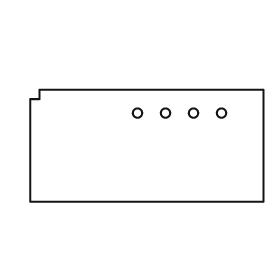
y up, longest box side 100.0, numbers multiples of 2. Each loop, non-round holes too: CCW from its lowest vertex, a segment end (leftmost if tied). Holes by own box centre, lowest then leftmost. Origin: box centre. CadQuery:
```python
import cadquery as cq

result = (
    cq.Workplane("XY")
    .moveTo(-50.0, -24.0)
    .lineTo(50.0, -24.0)
    .lineTo(50.0, 24.0)
    .lineTo(-46.0, 24.0)
    .lineTo(-46.0, 20.0)
    .lineTo(-50.0, 20.0)
    .close()
    .moveTo(-4.0, 14.0)
    .circle(2.0)
    .moveTo(8.0, 14.0)
    .circle(2.0)
    .moveTo(20.0, 14.0)
    .circle(2.0)
    .moveTo(32.0, 14.0)
    .circle(2.0)
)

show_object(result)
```